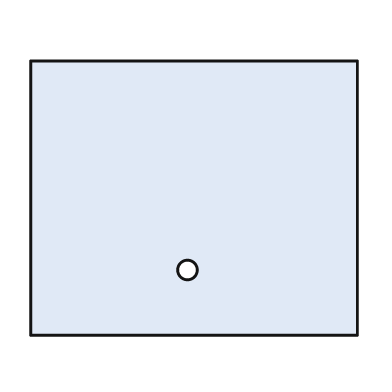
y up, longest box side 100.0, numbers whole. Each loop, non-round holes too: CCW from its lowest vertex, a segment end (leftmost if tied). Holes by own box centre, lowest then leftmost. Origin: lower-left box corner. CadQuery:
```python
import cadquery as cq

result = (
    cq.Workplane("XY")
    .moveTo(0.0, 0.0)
    .lineTo(100.0, 0.0)
    .lineTo(100.0, 84.0)
    .lineTo(0.0, 84.0)
    .close()
    .moveTo(48.0, 20.0)
    .circle(3.0)
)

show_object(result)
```